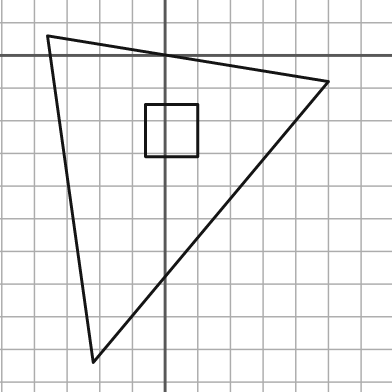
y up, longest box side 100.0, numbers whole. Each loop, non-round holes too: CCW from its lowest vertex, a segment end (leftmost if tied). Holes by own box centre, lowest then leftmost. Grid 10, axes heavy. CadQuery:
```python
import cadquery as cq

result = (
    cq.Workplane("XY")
    .moveTo(-22.0, -94.0)
    .lineTo(50.0, -8.0)
    .lineTo(-36.0, 6.0)
    .close()
    .moveTo(-6.0, -31.0)
    .lineTo(10.0, -31.0)
    .lineTo(10.0, -15.0)
    .lineTo(-6.0, -15.0)
    .close()
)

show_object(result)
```